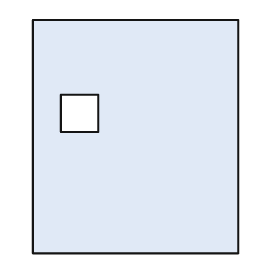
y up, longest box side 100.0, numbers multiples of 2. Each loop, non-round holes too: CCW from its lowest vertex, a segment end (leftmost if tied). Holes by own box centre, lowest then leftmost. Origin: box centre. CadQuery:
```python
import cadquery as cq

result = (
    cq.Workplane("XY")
    .moveTo(-44.0, -50.0)
    .lineTo(44.0, -50.0)
    .lineTo(44.0, 50.0)
    .lineTo(-44.0, 50.0)
    .close()
    .moveTo(-32.0, 2.0)
    .lineTo(-16.0, 2.0)
    .lineTo(-16.0, 18.0)
    .lineTo(-32.0, 18.0)
    .close()
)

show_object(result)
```